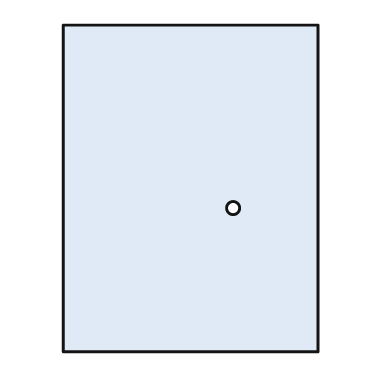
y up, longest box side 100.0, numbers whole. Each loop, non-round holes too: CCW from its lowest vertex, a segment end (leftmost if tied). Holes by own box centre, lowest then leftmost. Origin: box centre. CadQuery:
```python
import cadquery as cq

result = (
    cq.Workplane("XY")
    .moveTo(-39.0, -50.0)
    .lineTo(39.0, -50.0)
    .lineTo(39.0, 50.0)
    .lineTo(-39.0, 50.0)
    .close()
    .moveTo(13.0, -6.0)
    .circle(2.0)
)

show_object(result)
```